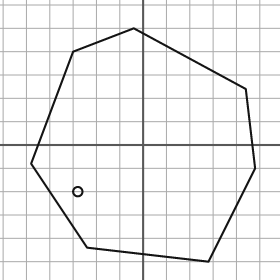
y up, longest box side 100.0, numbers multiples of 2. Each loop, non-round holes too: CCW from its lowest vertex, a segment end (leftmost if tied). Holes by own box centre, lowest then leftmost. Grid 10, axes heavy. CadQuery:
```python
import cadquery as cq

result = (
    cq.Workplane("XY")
    .moveTo(28.0, -50.0)
    .lineTo(48.0, -10.0)
    .lineTo(44.0, 24.0)
    .lineTo(-4.0, 50.0)
    .lineTo(-30.0, 40.0)
    .lineTo(-48.0, -8.0)
    .lineTo(-24.0, -44.0)
    .close()
    .moveTo(-28.0, -20.0)
    .circle(2.0)
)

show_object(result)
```